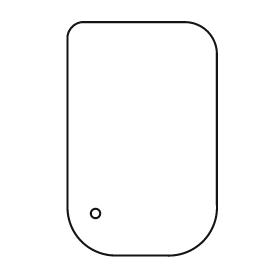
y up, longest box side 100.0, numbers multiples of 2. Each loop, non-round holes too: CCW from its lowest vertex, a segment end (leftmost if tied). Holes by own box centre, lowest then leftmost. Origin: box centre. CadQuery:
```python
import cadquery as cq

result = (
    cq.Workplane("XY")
    .moveTo(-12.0, -50.0)
    .lineTo(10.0, -50.0)
    .threePointArc((26.0, -44.0), (32.0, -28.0))
    .lineTo(32.0, 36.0)
    .threePointArc((28.0, 46.0), (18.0, 50.0))
    .lineTo(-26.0, 50.0)
    .threePointArc((-30.0, 48.0), (-32.0, 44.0))
    .lineTo(-32.0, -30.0)
    .threePointArc((-26.0, -44.0), (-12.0, -50.0))
    .close()
    .moveTo(-20.0, -32.0)
    .circle(2.0)
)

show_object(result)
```